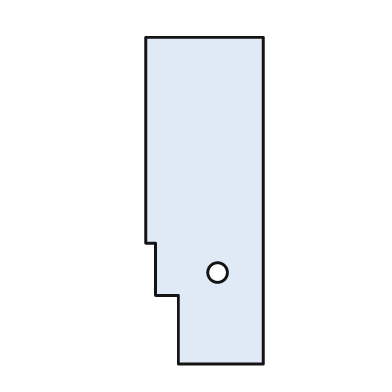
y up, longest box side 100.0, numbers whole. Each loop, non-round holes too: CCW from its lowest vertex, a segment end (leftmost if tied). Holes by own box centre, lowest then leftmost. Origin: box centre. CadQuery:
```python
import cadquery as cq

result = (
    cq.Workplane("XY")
    .moveTo(-8.0, -50.0)
    .lineTo(18.0, -50.0)
    .lineTo(18.0, 50.0)
    .lineTo(-18.0, 50.0)
    .lineTo(-18.0, -13.0)
    .lineTo(-15.0, -13.0)
    .lineTo(-15.0, -29.0)
    .lineTo(-8.0, -29.0)
    .close()
    .moveTo(4.0, -22.0)
    .circle(3.0)
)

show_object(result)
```